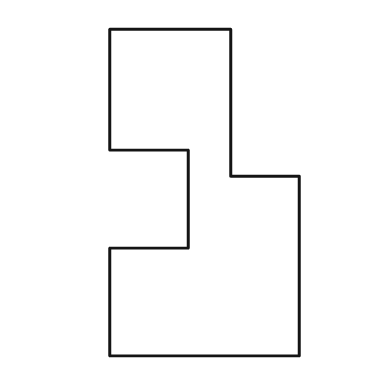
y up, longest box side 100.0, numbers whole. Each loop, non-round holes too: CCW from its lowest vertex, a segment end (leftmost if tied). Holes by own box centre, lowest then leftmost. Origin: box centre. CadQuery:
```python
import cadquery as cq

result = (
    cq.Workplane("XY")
    .moveTo(-29.0, -50.0)
    .lineTo(29.0, -50.0)
    .lineTo(29.0, 5.0)
    .lineTo(8.0, 5.0)
    .lineTo(8.0, 50.0)
    .lineTo(-29.0, 50.0)
    .lineTo(-29.0, 13.0)
    .lineTo(-5.0, 13.0)
    .lineTo(-5.0, -17.0)
    .lineTo(-29.0, -17.0)
    .close()
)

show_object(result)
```